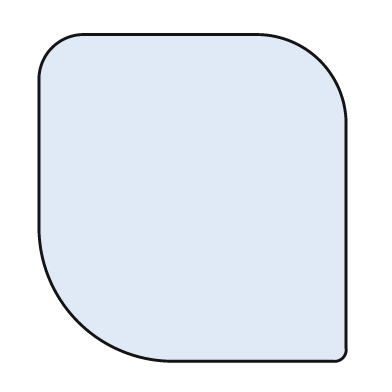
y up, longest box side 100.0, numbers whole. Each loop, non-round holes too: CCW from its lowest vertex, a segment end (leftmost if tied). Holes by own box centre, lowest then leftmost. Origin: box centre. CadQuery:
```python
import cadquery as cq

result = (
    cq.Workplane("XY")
    .moveTo(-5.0, -50.0)
    .lineTo(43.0, -50.0)
    .threePointArc((46.0, -49.0), (47.0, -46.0))
    .lineTo(47.0, 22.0)
    .threePointArc((39.0, 42.0), (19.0, 50.0))
    .lineTo(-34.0, 50.0)
    .threePointArc((-43.0, 46.0), (-47.0, 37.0))
    .lineTo(-47.0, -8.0)
    .threePointArc((-35.0, -38.0), (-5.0, -50.0))
    .close()
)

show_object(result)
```